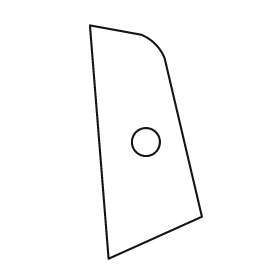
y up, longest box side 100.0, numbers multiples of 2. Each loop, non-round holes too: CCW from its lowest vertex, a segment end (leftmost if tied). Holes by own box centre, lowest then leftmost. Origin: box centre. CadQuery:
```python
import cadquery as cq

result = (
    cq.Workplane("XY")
    .moveTo(-16.0, -50.0)
    .lineTo(24.0, -32.0)
    .lineTo(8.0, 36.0)
    .threePointArc((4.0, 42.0), (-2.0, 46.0))
    .lineTo(-24.0, 50.0)
    .close()
    .moveTo(0.0, 0.0)
    .circle(6.0)
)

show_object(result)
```